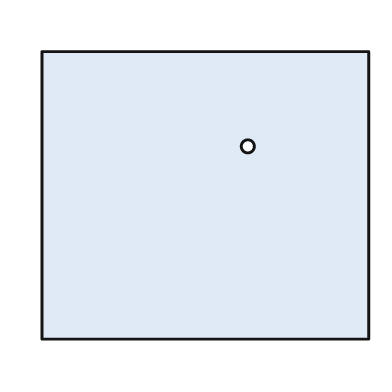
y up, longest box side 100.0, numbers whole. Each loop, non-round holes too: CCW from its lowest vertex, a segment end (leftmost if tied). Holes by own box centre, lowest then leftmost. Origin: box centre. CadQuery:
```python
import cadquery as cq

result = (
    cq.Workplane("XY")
    .moveTo(-50.0, -44.0)
    .lineTo(50.0, -44.0)
    .lineTo(50.0, 44.0)
    .lineTo(-50.0, 44.0)
    .close()
    .moveTo(13.0, 15.0)
    .circle(2.0)
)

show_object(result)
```